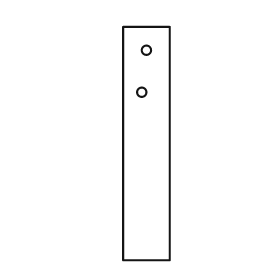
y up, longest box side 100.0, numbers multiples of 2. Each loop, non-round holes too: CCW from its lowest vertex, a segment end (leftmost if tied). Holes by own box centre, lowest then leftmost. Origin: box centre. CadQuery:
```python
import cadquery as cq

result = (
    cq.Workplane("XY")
    .moveTo(-10.0, -50.0)
    .lineTo(10.0, -50.0)
    .lineTo(10.0, 50.0)
    .lineTo(-10.0, 50.0)
    .close()
    .moveTo(-2.0, 22.0)
    .circle(2.0)
    .moveTo(0.0, 40.0)
    .circle(2.0)
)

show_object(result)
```